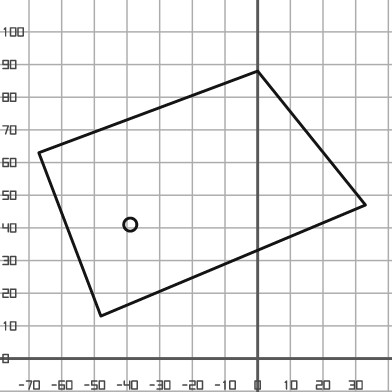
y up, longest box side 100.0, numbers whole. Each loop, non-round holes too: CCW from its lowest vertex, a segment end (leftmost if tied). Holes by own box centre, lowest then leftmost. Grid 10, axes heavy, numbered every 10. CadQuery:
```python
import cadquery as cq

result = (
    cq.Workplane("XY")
    .moveTo(-48.0, 13.0)
    .lineTo(33.0, 47.0)
    .lineTo(0.0, 88.0)
    .lineTo(-67.0, 63.0)
    .close()
    .moveTo(-39.0, 41.0)
    .circle(2.0)
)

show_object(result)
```